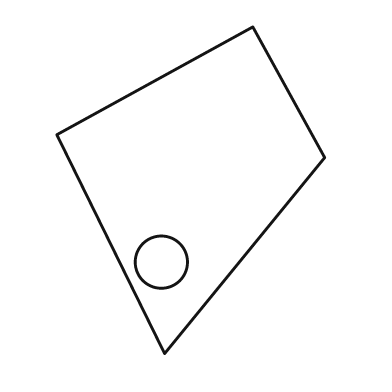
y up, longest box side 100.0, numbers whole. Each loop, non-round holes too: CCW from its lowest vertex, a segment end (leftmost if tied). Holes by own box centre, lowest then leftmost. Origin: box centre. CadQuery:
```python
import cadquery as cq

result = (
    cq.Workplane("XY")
    .moveTo(-8.0, -50.0)
    .lineTo(41.0, 10.0)
    .lineTo(19.0, 50.0)
    .lineTo(-41.0, 17.0)
    .close()
    .moveTo(-9.0, -22.0)
    .circle(8.0)
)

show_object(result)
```